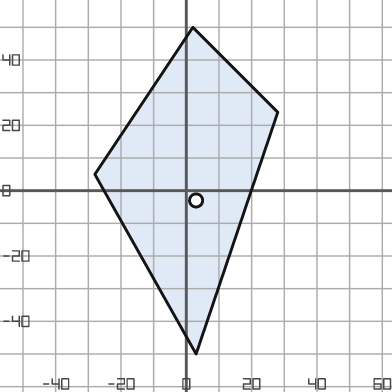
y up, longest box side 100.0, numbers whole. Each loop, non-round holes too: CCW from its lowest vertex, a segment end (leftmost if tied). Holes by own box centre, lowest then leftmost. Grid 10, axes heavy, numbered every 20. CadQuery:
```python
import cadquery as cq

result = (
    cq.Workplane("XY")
    .moveTo(3.0, -50.0)
    .lineTo(28.0, 24.0)
    .lineTo(2.0, 50.0)
    .lineTo(-28.0, 5.0)
    .close()
    .moveTo(3.0, -3.0)
    .circle(2.0)
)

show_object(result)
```